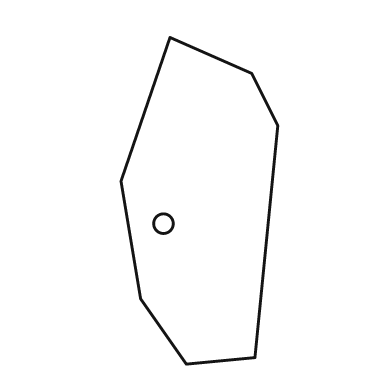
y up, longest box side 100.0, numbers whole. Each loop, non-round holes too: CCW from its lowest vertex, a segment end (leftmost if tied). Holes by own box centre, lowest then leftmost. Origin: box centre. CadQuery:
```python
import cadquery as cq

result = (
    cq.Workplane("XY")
    .moveTo(-4.0, -50.0)
    .lineTo(17.0, -48.0)
    .lineTo(24.0, 23.0)
    .lineTo(16.0, 39.0)
    .lineTo(-9.0, 50.0)
    .lineTo(-24.0, 6.0)
    .lineTo(-18.0, -30.0)
    .close()
    .moveTo(-11.0, -7.0)
    .circle(3.0)
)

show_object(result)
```